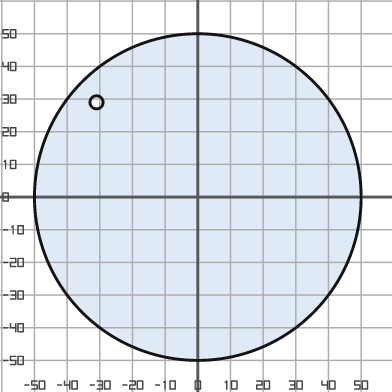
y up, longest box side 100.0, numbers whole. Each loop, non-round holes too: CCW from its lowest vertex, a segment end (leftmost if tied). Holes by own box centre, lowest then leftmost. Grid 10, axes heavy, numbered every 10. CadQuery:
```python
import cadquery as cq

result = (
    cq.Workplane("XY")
    .moveTo(0.0, 0.0)
    .circle(50.0)
    .moveTo(-31.0, 29.0)
    .circle(2.0)
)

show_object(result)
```